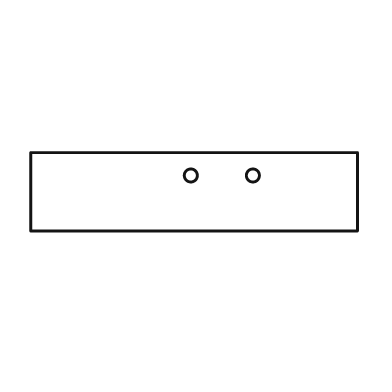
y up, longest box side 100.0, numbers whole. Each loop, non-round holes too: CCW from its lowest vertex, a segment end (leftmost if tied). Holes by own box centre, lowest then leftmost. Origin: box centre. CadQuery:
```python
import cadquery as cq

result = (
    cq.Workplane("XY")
    .moveTo(-50.0, -12.0)
    .lineTo(50.0, -12.0)
    .lineTo(50.0, 12.0)
    .lineTo(-50.0, 12.0)
    .close()
    .moveTo(-1.0, 5.0)
    .circle(2.0)
    .moveTo(18.0, 5.0)
    .circle(2.0)
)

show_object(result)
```